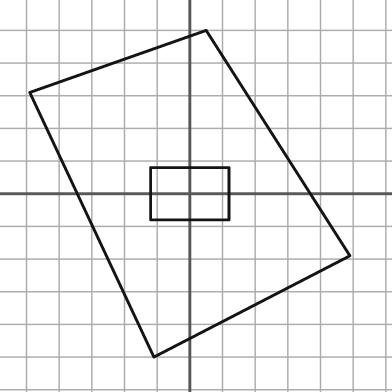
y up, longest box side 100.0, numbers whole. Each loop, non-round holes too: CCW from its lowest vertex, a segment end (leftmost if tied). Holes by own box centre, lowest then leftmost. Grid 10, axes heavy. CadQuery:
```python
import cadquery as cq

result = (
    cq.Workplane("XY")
    .moveTo(-11.0, -50.0)
    .lineTo(49.0, -19.0)
    .lineTo(5.0, 50.0)
    .lineTo(-49.0, 31.0)
    .close()
    .moveTo(-12.0, -8.0)
    .lineTo(12.0, -8.0)
    .lineTo(12.0, 8.0)
    .lineTo(-12.0, 8.0)
    .close()
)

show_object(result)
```